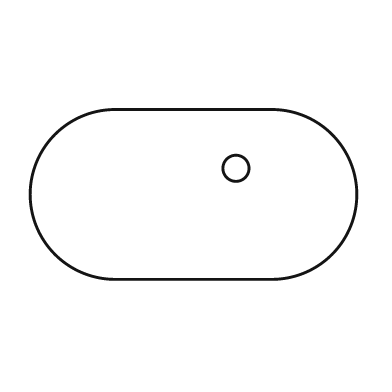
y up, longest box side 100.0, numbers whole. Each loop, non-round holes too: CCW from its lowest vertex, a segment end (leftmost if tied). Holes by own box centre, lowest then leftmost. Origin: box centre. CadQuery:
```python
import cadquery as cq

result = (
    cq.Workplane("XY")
    .moveTo(-24.0, -26.0)
    .lineTo(24.0, -26.0)
    .threePointArc((50.0, 0.0), (24.0, 26.0))
    .lineTo(-24.0, 26.0)
    .threePointArc((-50.0, 0.0), (-24.0, -26.0))
    .close()
    .moveTo(13.0, 8.0)
    .circle(4.0)
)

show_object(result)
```